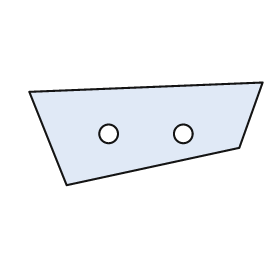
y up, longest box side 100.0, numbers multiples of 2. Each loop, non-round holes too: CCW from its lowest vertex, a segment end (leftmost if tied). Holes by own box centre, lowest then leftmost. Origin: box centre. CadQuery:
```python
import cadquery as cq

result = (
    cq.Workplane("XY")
    .moveTo(-34.0, -22.0)
    .lineTo(40.0, -6.0)
    .lineTo(50.0, 22.0)
    .lineTo(-50.0, 18.0)
    .close()
    .moveTo(-16.0, 0.0)
    .circle(4.0)
    .moveTo(16.0, 0.0)
    .circle(4.0)
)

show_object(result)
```